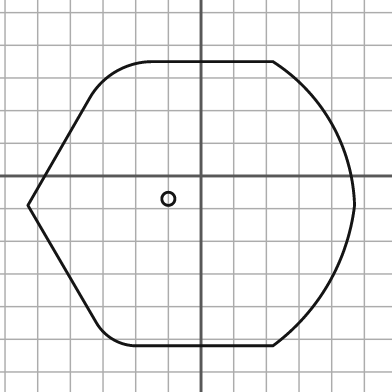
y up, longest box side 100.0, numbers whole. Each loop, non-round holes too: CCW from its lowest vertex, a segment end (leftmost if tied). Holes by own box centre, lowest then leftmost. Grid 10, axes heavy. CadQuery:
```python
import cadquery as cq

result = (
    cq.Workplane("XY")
    .moveTo(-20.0, -52.0)
    .lineTo(22.0, -52.0)
    .threePointArc((39.0, -33.0), (47.0, -9.0))
    .threePointArc((40.0, 16.0), (22.0, 35.0))
    .lineTo(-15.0, 35.0)
    .threePointArc((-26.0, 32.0), (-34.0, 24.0))
    .lineTo(-53.0, -9.0)
    .lineTo(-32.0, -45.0)
    .threePointArc((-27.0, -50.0), (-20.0, -52.0))
    .close()
    .moveTo(-10.0, -7.0)
    .circle(2.0)
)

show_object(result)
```